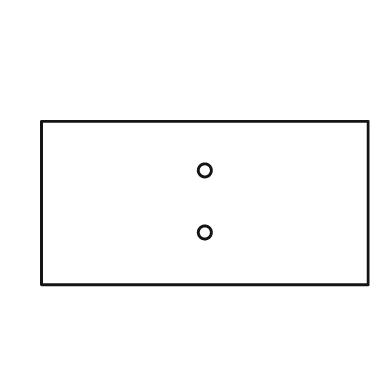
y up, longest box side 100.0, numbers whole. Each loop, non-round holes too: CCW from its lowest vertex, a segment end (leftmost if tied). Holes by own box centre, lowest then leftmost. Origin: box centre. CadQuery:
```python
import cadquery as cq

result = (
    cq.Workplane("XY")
    .moveTo(-50.0, -25.0)
    .lineTo(50.0, -25.0)
    .lineTo(50.0, 25.0)
    .lineTo(-50.0, 25.0)
    .close()
    .moveTo(0.0, -9.0)
    .circle(2.0)
    .moveTo(0.0, 10.0)
    .circle(2.0)
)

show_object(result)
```